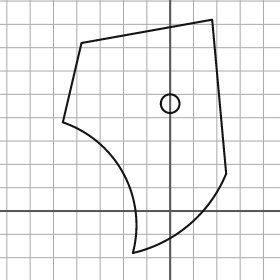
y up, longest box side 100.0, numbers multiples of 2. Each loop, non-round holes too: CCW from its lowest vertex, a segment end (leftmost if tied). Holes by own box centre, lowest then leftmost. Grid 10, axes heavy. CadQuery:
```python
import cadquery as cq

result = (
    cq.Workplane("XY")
    .moveTo(-16.0, -18.0)
    .threePointArc((8.0, -6.0), (24.0, 16.0))
    .lineTo(18.0, 82.0)
    .lineTo(-38.0, 72.0)
    .lineTo(-46.0, 38.0)
    .threePointArc((-20.0, 16.0), (-16.0, -18.0))
    .close()
    .moveTo(0.0, 46.0)
    .circle(4.0)
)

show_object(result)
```